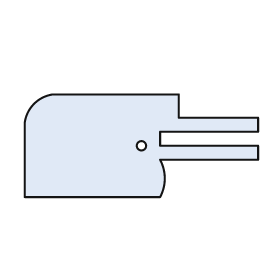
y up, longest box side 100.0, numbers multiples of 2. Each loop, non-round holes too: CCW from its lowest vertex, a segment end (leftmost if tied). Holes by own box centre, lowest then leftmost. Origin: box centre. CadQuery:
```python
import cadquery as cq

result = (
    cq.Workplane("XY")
    .moveTo(-50.0, -22.0)
    .lineTo(8.0, -22.0)
    .threePointArc((10.0, -14.0), (8.0, -6.0))
    .lineTo(50.0, -6.0)
    .lineTo(50.0, 0.0)
    .lineTo(8.0, 0.0)
    .lineTo(8.0, 6.0)
    .lineTo(50.0, 6.0)
    .lineTo(50.0, 12.0)
    .lineTo(16.0, 12.0)
    .lineTo(16.0, 22.0)
    .lineTo(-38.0, 22.0)
    .threePointArc((-46.0, 18.0), (-50.0, 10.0))
    .close()
    .moveTo(0.0, 0.0)
    .circle(2.0)
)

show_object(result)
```